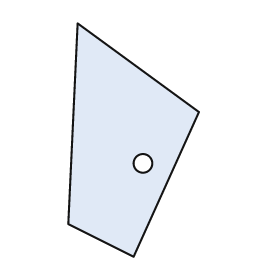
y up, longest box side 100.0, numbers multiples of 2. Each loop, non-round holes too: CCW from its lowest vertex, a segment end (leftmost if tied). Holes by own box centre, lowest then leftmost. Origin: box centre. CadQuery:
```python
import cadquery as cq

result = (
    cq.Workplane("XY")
    .moveTo(0.0, -50.0)
    .lineTo(28.0, 12.0)
    .lineTo(-24.0, 50.0)
    .lineTo(-28.0, -36.0)
    .close()
    .moveTo(4.0, -10.0)
    .circle(4.0)
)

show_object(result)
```